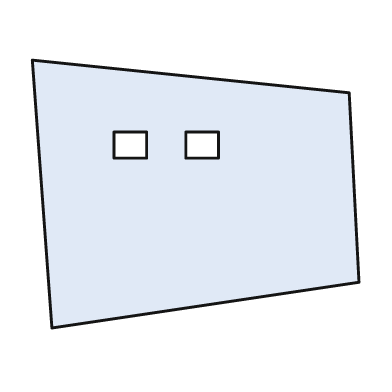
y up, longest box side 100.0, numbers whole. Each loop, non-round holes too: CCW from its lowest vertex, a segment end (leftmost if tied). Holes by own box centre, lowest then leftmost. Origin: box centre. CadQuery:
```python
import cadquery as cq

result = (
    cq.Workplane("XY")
    .moveTo(-44.0, -41.0)
    .lineTo(50.0, -27.0)
    .lineTo(47.0, 31.0)
    .lineTo(-50.0, 41.0)
    .close()
    .moveTo(-25.0, 11.0)
    .lineTo(-15.0, 11.0)
    .lineTo(-15.0, 19.0)
    .lineTo(-25.0, 19.0)
    .close()
    .moveTo(-3.0, 11.0)
    .lineTo(7.0, 11.0)
    .lineTo(7.0, 19.0)
    .lineTo(-3.0, 19.0)
    .close()
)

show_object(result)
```